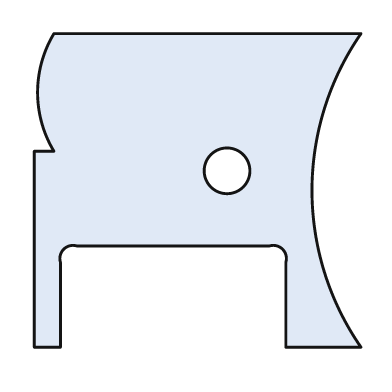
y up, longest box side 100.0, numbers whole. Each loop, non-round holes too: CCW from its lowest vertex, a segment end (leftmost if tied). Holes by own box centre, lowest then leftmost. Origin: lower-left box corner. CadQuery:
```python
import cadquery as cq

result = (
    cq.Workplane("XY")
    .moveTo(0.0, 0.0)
    .lineTo(8.0, 0.0)
    .lineTo(8.0, 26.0)
    .threePointArc((9.0, 30.0), (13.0, 31.0))
    .lineTo(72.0, 31.0)
    .threePointArc((76.0, 30.0), (77.0, 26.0))
    .lineTo(77.0, 0.0)
    .lineTo(100.0, 0.0)
    .threePointArc((85.0, 48.0), (100.0, 96.0))
    .lineTo(6.0, 96.0)
    .threePointArc((1.0, 78.0), (6.0, 60.0))
    .lineTo(0.0, 60.0)
    .close()
    .moveTo(59.0, 54.0)
    .circle(7.0)
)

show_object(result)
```